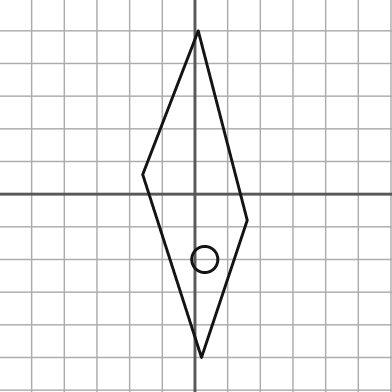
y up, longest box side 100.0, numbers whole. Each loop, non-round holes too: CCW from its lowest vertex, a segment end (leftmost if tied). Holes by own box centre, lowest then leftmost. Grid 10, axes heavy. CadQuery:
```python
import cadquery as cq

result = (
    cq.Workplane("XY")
    .moveTo(2.0, -50.0)
    .lineTo(16.0, -8.0)
    .lineTo(1.0, 50.0)
    .lineTo(-16.0, 6.0)
    .close()
    .moveTo(3.0, -20.0)
    .circle(4.0)
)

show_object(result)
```